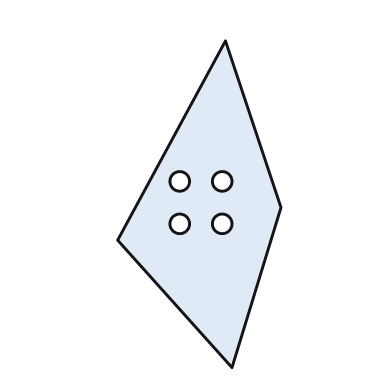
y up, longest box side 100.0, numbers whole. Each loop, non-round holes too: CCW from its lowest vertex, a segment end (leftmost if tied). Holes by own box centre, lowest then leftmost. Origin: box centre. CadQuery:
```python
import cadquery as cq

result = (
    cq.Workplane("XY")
    .moveTo(10.0, -50.0)
    .lineTo(25.0, -1.0)
    .lineTo(8.0, 50.0)
    .lineTo(-25.0, -11.0)
    .close()
    .moveTo(-6.0, -6.0)
    .circle(3.0)
    .moveTo(7.0, -6.0)
    .circle(3.0)
    .moveTo(-6.0, 7.0)
    .circle(3.0)
    .moveTo(7.0, 7.0)
    .circle(3.0)
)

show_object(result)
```